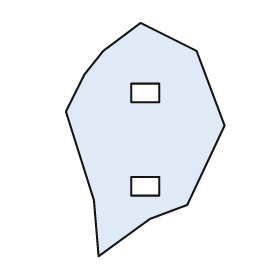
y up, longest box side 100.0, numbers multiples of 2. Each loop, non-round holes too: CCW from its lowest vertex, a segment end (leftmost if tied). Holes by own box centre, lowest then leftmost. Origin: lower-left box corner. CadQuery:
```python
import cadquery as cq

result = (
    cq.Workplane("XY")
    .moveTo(14.0, 0.0)
    .lineTo(36.0, 16.0)
    .lineTo(52.0, 22.0)
    .lineTo(68.0, 56.0)
    .lineTo(56.0, 88.0)
    .lineTo(32.0, 100.0)
    .lineTo(16.0, 88.0)
    .lineTo(8.0, 78.0)
    .lineTo(0.0, 62.0)
    .lineTo(12.0, 24.0)
    .close()
    .moveTo(28.0, 26.0)
    .lineTo(40.0, 26.0)
    .lineTo(40.0, 34.0)
    .lineTo(28.0, 34.0)
    .close()
    .moveTo(28.0, 66.0)
    .lineTo(40.0, 66.0)
    .lineTo(40.0, 74.0)
    .lineTo(28.0, 74.0)
    .close()
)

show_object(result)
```